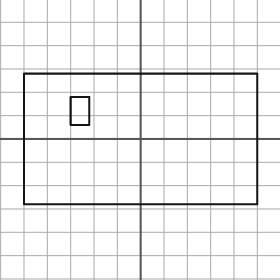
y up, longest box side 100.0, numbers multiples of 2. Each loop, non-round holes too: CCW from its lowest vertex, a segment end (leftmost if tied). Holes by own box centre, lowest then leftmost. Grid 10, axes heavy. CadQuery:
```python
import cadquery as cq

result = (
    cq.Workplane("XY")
    .moveTo(-50.0, -28.0)
    .lineTo(50.0, -28.0)
    .lineTo(50.0, 28.0)
    .lineTo(-50.0, 28.0)
    .close()
    .moveTo(-30.0, 6.0)
    .lineTo(-22.0, 6.0)
    .lineTo(-22.0, 18.0)
    .lineTo(-30.0, 18.0)
    .close()
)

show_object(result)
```